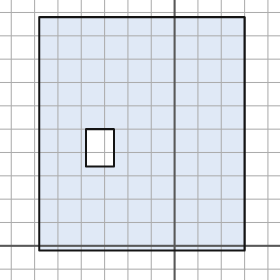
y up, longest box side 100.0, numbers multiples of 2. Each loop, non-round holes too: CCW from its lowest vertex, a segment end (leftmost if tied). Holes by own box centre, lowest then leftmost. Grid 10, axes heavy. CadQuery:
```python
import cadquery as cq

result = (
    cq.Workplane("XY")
    .moveTo(-58.0, -2.0)
    .lineTo(30.0, -2.0)
    .lineTo(30.0, 98.0)
    .lineTo(-58.0, 98.0)
    .close()
    .moveTo(-38.0, 34.0)
    .lineTo(-26.0, 34.0)
    .lineTo(-26.0, 50.0)
    .lineTo(-38.0, 50.0)
    .close()
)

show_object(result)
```